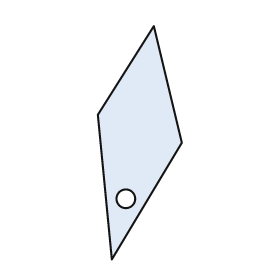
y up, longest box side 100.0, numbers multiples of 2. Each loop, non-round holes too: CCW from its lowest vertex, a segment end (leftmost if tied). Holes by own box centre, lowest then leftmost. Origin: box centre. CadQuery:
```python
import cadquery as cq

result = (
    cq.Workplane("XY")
    .moveTo(-12.0, -50.0)
    .lineTo(18.0, 0.0)
    .lineTo(6.0, 50.0)
    .lineTo(-18.0, 12.0)
    .close()
    .moveTo(-6.0, -24.0)
    .circle(4.0)
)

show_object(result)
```